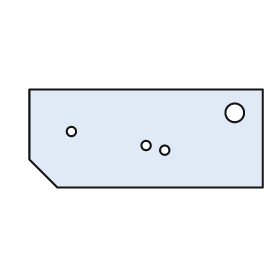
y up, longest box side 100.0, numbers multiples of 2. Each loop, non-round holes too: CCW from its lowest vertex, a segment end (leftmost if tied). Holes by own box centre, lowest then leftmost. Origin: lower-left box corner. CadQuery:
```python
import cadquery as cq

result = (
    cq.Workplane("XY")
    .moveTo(12.0, 0.0)
    .lineTo(100.0, 0.0)
    .lineTo(100.0, 42.0)
    .lineTo(0.0, 42.0)
    .lineTo(0.0, 12.0)
    .close()
    .moveTo(58.0, 16.0)
    .circle(2.0)
    .moveTo(50.0, 18.0)
    .circle(2.0)
    .moveTo(18.0, 24.0)
    .circle(2.0)
    .moveTo(88.0, 32.0)
    .circle(4.0)
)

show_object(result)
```